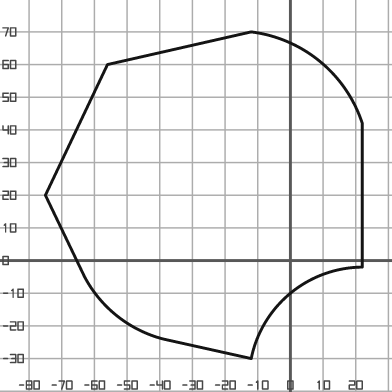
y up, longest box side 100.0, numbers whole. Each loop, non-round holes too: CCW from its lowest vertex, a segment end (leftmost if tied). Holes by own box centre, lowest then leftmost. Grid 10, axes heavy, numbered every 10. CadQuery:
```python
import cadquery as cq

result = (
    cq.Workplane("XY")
    .moveTo(-12.0, -30.0)
    .threePointArc((0.0, -10.0), (22.0, -2.0))
    .lineTo(22.0, 42.0)
    .threePointArc((9.0, 61.0), (-12.0, 70.0))
    .lineTo(-56.0, 60.0)
    .lineTo(-75.0, 20.0)
    .lineTo(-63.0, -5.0)
    .threePointArc((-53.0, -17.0), (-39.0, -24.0))
    .close()
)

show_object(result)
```